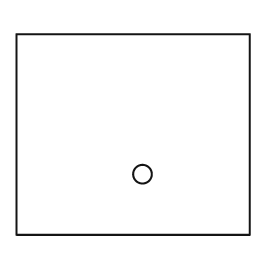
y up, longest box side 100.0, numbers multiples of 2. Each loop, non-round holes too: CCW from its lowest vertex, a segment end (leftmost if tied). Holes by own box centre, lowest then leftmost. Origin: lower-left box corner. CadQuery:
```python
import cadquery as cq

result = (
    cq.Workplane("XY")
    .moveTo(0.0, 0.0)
    .lineTo(100.0, 0.0)
    .lineTo(100.0, 86.0)
    .lineTo(0.0, 86.0)
    .close()
    .moveTo(54.0, 26.0)
    .circle(4.0)
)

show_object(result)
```